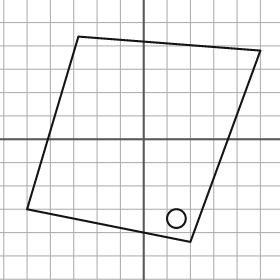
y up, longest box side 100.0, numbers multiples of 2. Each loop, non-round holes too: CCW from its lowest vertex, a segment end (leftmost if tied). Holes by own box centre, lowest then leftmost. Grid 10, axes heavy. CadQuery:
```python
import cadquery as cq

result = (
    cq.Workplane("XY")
    .moveTo(20.0, -44.0)
    .lineTo(50.0, 38.0)
    .lineTo(-28.0, 44.0)
    .lineTo(-50.0, -30.0)
    .close()
    .moveTo(14.0, -34.0)
    .circle(4.0)
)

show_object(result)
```